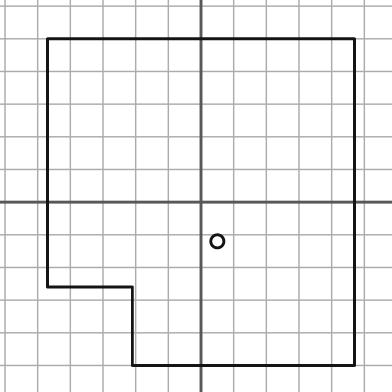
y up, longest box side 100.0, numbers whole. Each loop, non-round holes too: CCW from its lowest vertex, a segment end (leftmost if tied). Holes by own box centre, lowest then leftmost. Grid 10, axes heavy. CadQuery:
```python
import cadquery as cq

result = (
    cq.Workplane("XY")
    .moveTo(-21.0, -50.0)
    .lineTo(47.0, -50.0)
    .lineTo(47.0, 50.0)
    .lineTo(-47.0, 50.0)
    .lineTo(-47.0, -26.0)
    .lineTo(-21.0, -26.0)
    .close()
    .moveTo(5.0, -12.0)
    .circle(2.0)
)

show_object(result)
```